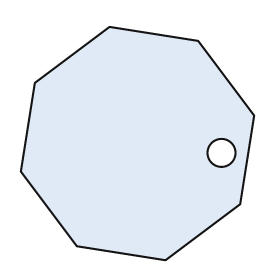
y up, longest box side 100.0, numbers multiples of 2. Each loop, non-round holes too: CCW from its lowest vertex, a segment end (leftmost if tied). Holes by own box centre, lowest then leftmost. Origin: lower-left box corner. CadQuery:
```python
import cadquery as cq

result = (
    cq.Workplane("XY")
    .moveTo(62.0, 0.0)
    .lineTo(94.0, 24.0)
    .lineTo(100.0, 62.0)
    .lineTo(76.0, 94.0)
    .lineTo(38.0, 100.0)
    .lineTo(6.0, 76.0)
    .lineTo(0.0, 38.0)
    .lineTo(24.0, 6.0)
    .close()
    .moveTo(86.0, 46.0)
    .circle(6.0)
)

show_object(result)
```